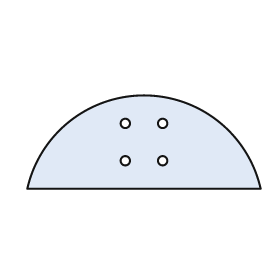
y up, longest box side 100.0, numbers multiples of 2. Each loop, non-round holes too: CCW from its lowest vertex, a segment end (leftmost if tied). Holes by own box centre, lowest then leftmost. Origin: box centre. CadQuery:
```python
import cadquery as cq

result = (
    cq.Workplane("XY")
    .moveTo(-50.0, -20.0)
    .lineTo(50.0, -20.0)
    .threePointArc((0.0, 20.0), (-50.0, -20.0))
    .close()
    .moveTo(-8.0, -8.0)
    .circle(2.0)
    .moveTo(8.0, -8.0)
    .circle(2.0)
    .moveTo(-8.0, 8.0)
    .circle(2.0)
    .moveTo(8.0, 8.0)
    .circle(2.0)
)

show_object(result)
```